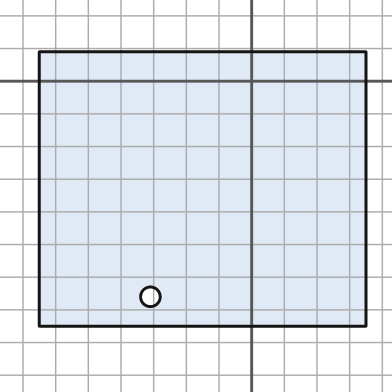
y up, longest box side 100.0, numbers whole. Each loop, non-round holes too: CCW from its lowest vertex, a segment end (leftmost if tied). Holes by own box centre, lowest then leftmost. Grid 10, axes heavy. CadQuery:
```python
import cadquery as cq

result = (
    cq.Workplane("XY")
    .moveTo(-65.0, -75.0)
    .lineTo(35.0, -75.0)
    .lineTo(35.0, 9.0)
    .lineTo(-65.0, 9.0)
    .close()
    .moveTo(-31.0, -66.0)
    .circle(3.0)
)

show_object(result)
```